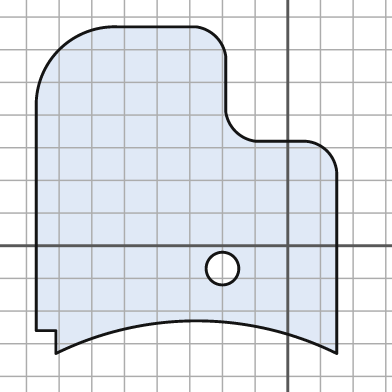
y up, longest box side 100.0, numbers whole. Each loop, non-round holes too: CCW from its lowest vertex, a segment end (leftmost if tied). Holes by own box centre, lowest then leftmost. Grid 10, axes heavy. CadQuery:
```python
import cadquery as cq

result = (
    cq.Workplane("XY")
    .moveTo(-71.0, -33.0)
    .threePointArc((-28.0, -23.0), (15.0, -33.0))
    .lineTo(15.0, 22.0)
    .threePointArc((12.0, 29.0), (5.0, 32.0))
    .lineTo(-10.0, 32.0)
    .threePointArc((-16.0, 35.0), (-19.0, 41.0))
    .lineTo(-19.0, 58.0)
    .threePointArc((-22.0, 64.0), (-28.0, 67.0))
    .lineTo(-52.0, 67.0)
    .threePointArc((-70.0, 60.0), (-77.0, 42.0))
    .lineTo(-77.0, -26.0)
    .lineTo(-71.0, -26.0)
    .close()
    .moveTo(-20.0, -7.0)
    .circle(5.0)
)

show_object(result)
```